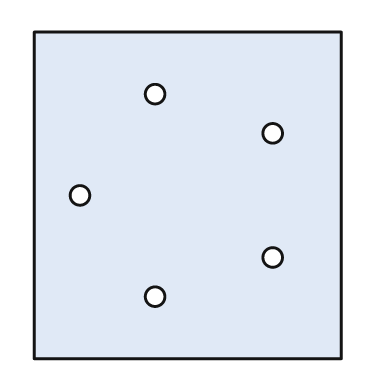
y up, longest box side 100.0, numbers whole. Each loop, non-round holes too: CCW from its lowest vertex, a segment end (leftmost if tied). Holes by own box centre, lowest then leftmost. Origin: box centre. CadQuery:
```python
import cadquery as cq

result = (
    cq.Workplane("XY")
    .moveTo(-47.0, -50.0)
    .lineTo(47.0, -50.0)
    .lineTo(47.0, 50.0)
    .lineTo(-47.0, 50.0)
    .close()
    .moveTo(-10.0, -31.0)
    .circle(3.0)
    .moveTo(26.0, -19.0)
    .circle(3.0)
    .moveTo(-33.0, 0.0)
    .circle(3.0)
    .moveTo(26.0, 19.0)
    .circle(3.0)
    .moveTo(-10.0, 31.0)
    .circle(3.0)
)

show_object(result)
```